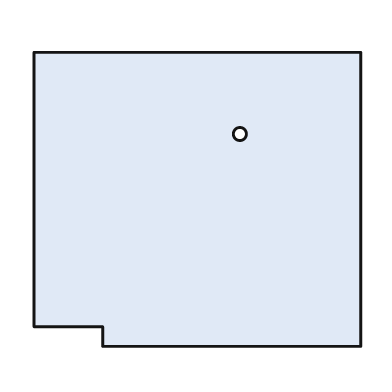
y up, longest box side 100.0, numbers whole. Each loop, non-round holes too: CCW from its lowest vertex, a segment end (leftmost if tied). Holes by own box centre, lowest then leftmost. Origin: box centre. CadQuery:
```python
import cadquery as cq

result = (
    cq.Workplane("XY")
    .moveTo(-29.0, -45.0)
    .lineTo(50.0, -45.0)
    .lineTo(50.0, 45.0)
    .lineTo(-50.0, 45.0)
    .lineTo(-50.0, -39.0)
    .lineTo(-29.0, -39.0)
    .close()
    .moveTo(13.0, 20.0)
    .circle(2.0)
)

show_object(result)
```